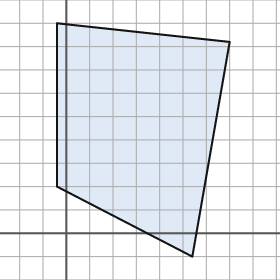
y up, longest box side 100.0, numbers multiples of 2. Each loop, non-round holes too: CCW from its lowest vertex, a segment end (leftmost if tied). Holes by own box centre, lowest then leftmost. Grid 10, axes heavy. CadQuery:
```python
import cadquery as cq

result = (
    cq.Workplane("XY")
    .moveTo(54.0, -10.0)
    .lineTo(70.0, 82.0)
    .lineTo(-4.0, 90.0)
    .lineTo(-4.0, 20.0)
    .close()
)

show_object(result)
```